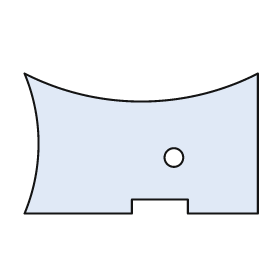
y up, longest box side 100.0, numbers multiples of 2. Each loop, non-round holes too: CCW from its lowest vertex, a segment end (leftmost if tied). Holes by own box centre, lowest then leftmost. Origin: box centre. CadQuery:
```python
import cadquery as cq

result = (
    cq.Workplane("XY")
    .moveTo(-50.0, -30.0)
    .lineTo(-4.0, -30.0)
    .lineTo(-4.0, -24.0)
    .lineTo(20.0, -24.0)
    .lineTo(20.0, -30.0)
    .lineTo(50.0, -30.0)
    .lineTo(50.0, 30.0)
    .threePointArc((0.0, 18.0), (-50.0, 30.0))
    .threePointArc((-44.0, 0.0), (-50.0, -30.0))
    .close()
    .moveTo(14.0, -6.0)
    .circle(4.0)
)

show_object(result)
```